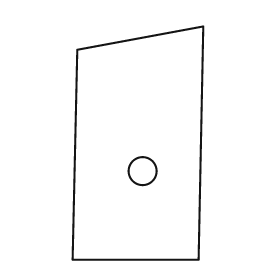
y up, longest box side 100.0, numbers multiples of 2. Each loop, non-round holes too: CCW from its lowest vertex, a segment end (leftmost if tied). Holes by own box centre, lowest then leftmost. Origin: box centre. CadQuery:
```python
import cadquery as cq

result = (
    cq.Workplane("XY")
    .moveTo(-28.0, -50.0)
    .lineTo(26.0, -50.0)
    .lineTo(28.0, 50.0)
    .lineTo(-26.0, 40.0)
    .close()
    .moveTo(2.0, -12.0)
    .circle(6.0)
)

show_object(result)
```